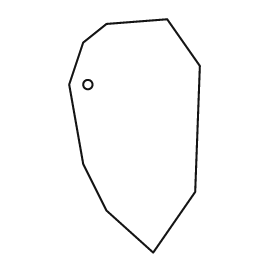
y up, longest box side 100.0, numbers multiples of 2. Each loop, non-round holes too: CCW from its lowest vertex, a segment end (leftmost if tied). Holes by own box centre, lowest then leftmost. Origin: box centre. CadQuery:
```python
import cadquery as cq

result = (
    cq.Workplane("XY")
    .moveTo(8.0, -50.0)
    .lineTo(26.0, -24.0)
    .lineTo(28.0, 30.0)
    .lineTo(14.0, 50.0)
    .lineTo(-12.0, 48.0)
    .lineTo(-22.0, 40.0)
    .lineTo(-28.0, 22.0)
    .lineTo(-22.0, -12.0)
    .lineTo(-12.0, -32.0)
    .close()
    .moveTo(-20.0, 22.0)
    .circle(2.0)
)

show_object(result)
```